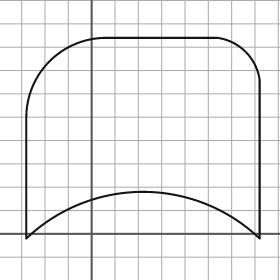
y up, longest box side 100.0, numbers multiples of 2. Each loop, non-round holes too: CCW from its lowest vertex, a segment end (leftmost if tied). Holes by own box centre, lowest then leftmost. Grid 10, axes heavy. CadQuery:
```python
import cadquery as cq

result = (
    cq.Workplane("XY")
    .moveTo(-28.0, -2.0)
    .threePointArc((22.0, 18.0), (72.0, -2.0))
    .lineTo(72.0, 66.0)
    .threePointArc((66.0, 78.0), (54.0, 84.0))
    .lineTo(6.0, 84.0)
    .threePointArc((-18.0, 74.0), (-28.0, 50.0))
    .close()
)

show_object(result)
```